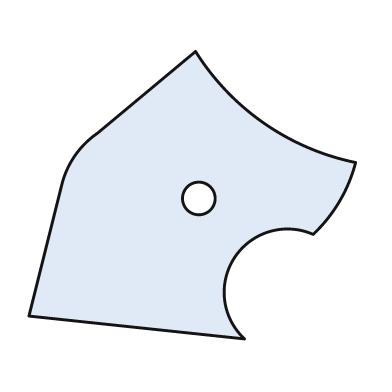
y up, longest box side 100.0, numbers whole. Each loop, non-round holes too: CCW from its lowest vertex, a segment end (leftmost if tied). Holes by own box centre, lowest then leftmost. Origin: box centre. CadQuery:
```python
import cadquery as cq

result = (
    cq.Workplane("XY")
    .moveTo(16.0, -44.0)
    .threePointArc((13.0, -19.0), (37.0, -12.0))
    .threePointArc((45.0, -2.0), (50.0, 10.0))
    .threePointArc((22.0, 22.0), (1.0, 44.0))
    .lineTo(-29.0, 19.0)
    .threePointArc((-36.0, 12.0), (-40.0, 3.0))
    .lineTo(-50.0, -37.0)
    .close()
    .moveTo(2.0, -1.0)
    .circle(5.0)
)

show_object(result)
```